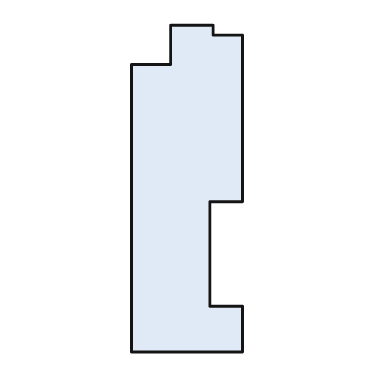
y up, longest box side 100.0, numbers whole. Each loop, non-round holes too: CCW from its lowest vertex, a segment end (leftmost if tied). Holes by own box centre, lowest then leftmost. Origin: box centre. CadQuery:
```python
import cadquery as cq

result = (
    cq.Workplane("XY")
    .moveTo(-17.0, -50.0)
    .lineTo(17.0, -50.0)
    .lineTo(17.0, -36.0)
    .lineTo(7.0, -36.0)
    .lineTo(7.0, -4.0)
    .lineTo(17.0, -4.0)
    .lineTo(17.0, 47.0)
    .lineTo(8.0, 47.0)
    .lineTo(8.0, 50.0)
    .lineTo(-5.0, 50.0)
    .lineTo(-5.0, 38.0)
    .lineTo(-17.0, 38.0)
    .close()
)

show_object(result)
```